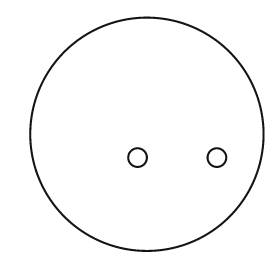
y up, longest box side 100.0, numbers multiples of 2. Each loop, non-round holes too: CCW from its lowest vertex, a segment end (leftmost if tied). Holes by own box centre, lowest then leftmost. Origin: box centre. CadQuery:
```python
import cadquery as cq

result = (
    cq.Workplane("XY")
    .moveTo(0.0, 0.0)
    .circle(50.0)
    .moveTo(-4.0, -10.0)
    .circle(4.0)
    .moveTo(30.0, -10.0)
    .circle(4.0)
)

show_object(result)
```